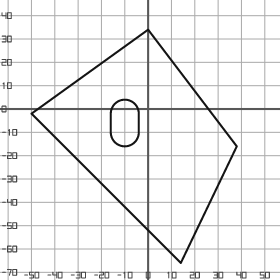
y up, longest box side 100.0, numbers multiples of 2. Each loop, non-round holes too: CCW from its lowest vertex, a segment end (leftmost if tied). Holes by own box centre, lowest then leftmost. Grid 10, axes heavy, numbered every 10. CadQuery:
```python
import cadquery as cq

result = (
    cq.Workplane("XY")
    .moveTo(14.0, -66.0)
    .lineTo(38.0, -16.0)
    .lineTo(0.0, 34.0)
    .lineTo(-50.0, -2.0)
    .close()
    .moveTo(-16.0, -10.0)
    .threePointArc((-10.0, -16.0), (-4.0, -10.0))
    .lineTo(-4.0, -2.0)
    .threePointArc((-10.0, 4.0), (-16.0, -2.0))
    .close()
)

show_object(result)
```